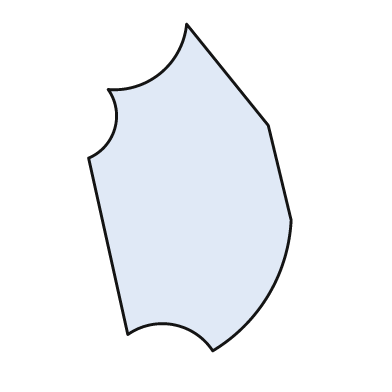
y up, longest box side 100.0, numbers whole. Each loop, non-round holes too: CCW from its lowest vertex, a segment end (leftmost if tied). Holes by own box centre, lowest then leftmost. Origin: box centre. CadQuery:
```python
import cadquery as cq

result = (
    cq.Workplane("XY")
    .moveTo(7.0, -50.0)
    .threePointArc((24.0, -33.0), (31.0, -10.0))
    .lineTo(24.0, 19.0)
    .lineTo(-1.0, 50.0)
    .threePointArc((-9.0, 35.0), (-25.0, 30.0))
    .threePointArc((-23.0, 18.0), (-31.0, 9.0))
    .lineTo(-19.0, -45.0)
    .threePointArc((-5.0, -42.0), (7.0, -50.0))
    .close()
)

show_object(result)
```